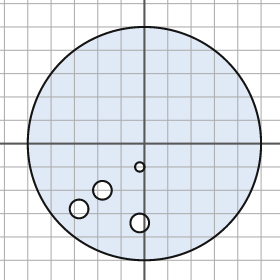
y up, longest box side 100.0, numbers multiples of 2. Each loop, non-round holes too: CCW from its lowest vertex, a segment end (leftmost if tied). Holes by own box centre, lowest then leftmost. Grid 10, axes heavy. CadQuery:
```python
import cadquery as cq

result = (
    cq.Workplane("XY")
    .moveTo(0.0, 0.0)
    .circle(50.0)
    .moveTo(-2.0, -34.0)
    .circle(4.0)
    .moveTo(-28.0, -28.0)
    .circle(4.0)
    .moveTo(-18.0, -20.0)
    .circle(4.0)
    .moveTo(-2.0, -10.0)
    .circle(2.0)
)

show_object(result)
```